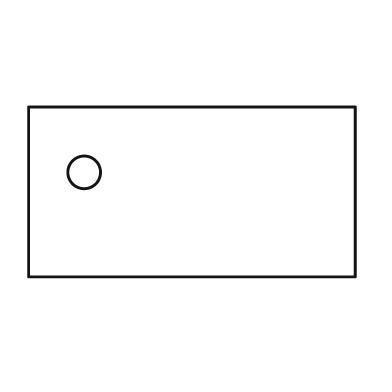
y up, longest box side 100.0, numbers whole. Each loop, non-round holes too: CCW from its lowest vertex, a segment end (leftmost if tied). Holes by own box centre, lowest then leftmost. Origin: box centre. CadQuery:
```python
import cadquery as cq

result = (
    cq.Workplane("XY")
    .moveTo(-50.0, -26.0)
    .lineTo(50.0, -26.0)
    .lineTo(50.0, 26.0)
    .lineTo(-50.0, 26.0)
    .close()
    .moveTo(-33.0, 6.0)
    .circle(5.0)
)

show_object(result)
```